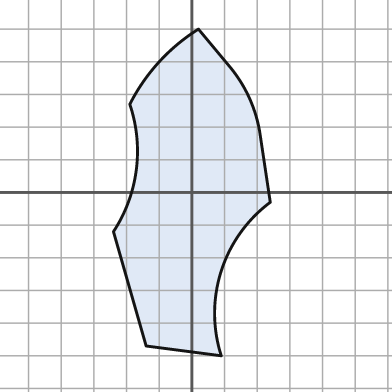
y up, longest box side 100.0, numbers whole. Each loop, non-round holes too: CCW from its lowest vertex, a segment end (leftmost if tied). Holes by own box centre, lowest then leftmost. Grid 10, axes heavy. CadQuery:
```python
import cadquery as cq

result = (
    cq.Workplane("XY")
    .moveTo(9.0, -50.0)
    .threePointArc((9.0, -24.0), (24.0, -3.0))
    .lineTo(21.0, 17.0)
    .threePointArc((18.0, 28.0), (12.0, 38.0))
    .lineTo(2.0, 50.0)
    .threePointArc((-10.0, 40.0), (-19.0, 27.0))
    .threePointArc((-17.0, 7.0), (-24.0, -12.0))
    .lineTo(-14.0, -47.0)
    .close()
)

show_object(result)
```